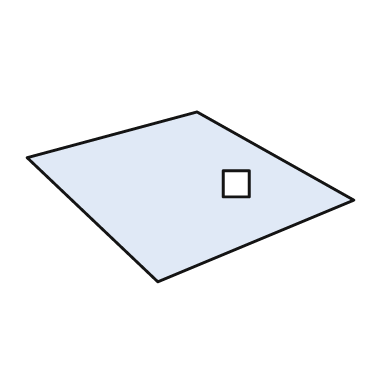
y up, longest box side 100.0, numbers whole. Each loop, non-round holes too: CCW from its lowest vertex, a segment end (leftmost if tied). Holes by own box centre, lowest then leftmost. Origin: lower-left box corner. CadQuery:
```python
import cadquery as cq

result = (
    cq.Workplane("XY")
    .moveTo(40.0, 0.0)
    .lineTo(100.0, 25.0)
    .lineTo(52.0, 52.0)
    .lineTo(0.0, 38.0)
    .close()
    .moveTo(60.0, 26.0)
    .lineTo(68.0, 26.0)
    .lineTo(68.0, 34.0)
    .lineTo(60.0, 34.0)
    .close()
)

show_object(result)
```